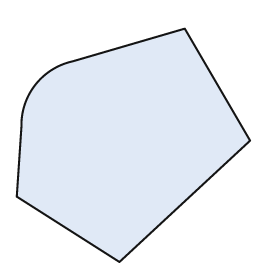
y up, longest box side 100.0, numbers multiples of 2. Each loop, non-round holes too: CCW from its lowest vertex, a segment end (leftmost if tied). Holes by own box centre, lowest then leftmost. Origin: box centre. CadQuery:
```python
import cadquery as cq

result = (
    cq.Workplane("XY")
    .moveTo(-6.0, -50.0)
    .lineTo(50.0, 2.0)
    .lineTo(22.0, 50.0)
    .lineTo(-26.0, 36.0)
    .threePointArc((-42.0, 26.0), (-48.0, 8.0))
    .lineTo(-50.0, -22.0)
    .close()
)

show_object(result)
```